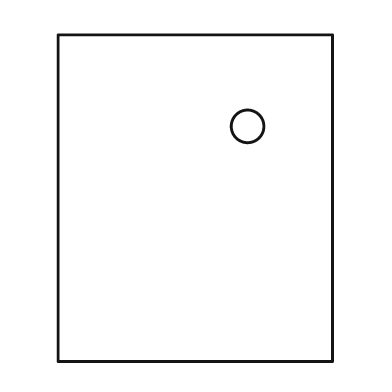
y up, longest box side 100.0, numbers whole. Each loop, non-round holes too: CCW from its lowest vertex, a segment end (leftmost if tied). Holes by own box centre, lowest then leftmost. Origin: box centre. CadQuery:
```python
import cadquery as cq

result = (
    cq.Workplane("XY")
    .moveTo(-42.0, -50.0)
    .lineTo(42.0, -50.0)
    .lineTo(42.0, 50.0)
    .lineTo(-42.0, 50.0)
    .close()
    .moveTo(16.0, 22.0)
    .circle(5.0)
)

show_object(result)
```